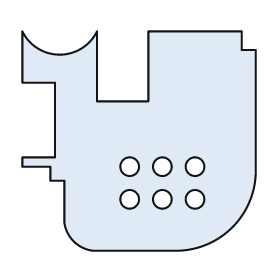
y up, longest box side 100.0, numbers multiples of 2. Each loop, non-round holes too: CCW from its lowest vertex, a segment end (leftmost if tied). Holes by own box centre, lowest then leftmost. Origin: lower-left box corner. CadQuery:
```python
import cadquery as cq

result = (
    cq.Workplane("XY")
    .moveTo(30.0, 0.0)
    .lineTo(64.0, 0.0)
    .threePointArc((90.0, 10.0), (100.0, 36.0))
    .lineTo(100.0, 86.0)
    .lineTo(94.0, 86.0)
    .lineTo(94.0, 94.0)
    .lineTo(54.0, 94.0)
    .lineTo(54.0, 64.0)
    .lineTo(32.0, 64.0)
    .lineTo(32.0, 94.0)
    .threePointArc((16.0, 84.0), (0.0, 94.0))
    .lineTo(0.0, 72.0)
    .lineTo(14.0, 72.0)
    .lineTo(14.0, 40.0)
    .lineTo(0.0, 40.0)
    .lineTo(0.0, 36.0)
    .lineTo(12.0, 36.0)
    .lineTo(12.0, 30.0)
    .lineTo(18.0, 30.0)
    .lineTo(18.0, 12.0)
    .threePointArc((22.0, 4.0), (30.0, 0.0))
    .close()
    .moveTo(46.0, 22.0)
    .circle(4.0)
    .moveTo(60.0, 22.0)
    .circle(4.0)
    .moveTo(74.0, 22.0)
    .circle(4.0)
    .moveTo(46.0, 36.0)
    .circle(4.0)
    .moveTo(60.0, 36.0)
    .circle(4.0)
    .moveTo(74.0, 36.0)
    .circle(4.0)
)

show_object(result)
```